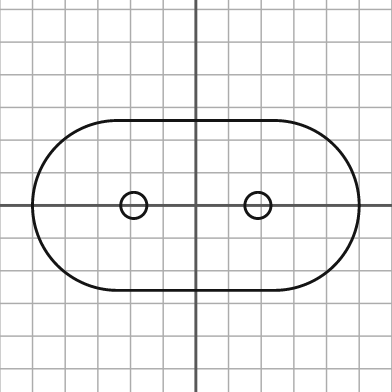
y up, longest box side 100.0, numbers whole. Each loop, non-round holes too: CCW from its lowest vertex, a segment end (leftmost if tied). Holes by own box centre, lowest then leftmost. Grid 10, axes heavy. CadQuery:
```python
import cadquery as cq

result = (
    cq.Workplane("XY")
    .moveTo(-24.0, -26.0)
    .lineTo(24.0, -26.0)
    .threePointArc((50.0, 0.0), (24.0, 26.0))
    .lineTo(-24.0, 26.0)
    .threePointArc((-50.0, 0.0), (-24.0, -26.0))
    .close()
    .moveTo(-19.0, 0.0)
    .circle(4.0)
    .moveTo(19.0, 0.0)
    .circle(4.0)
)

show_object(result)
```